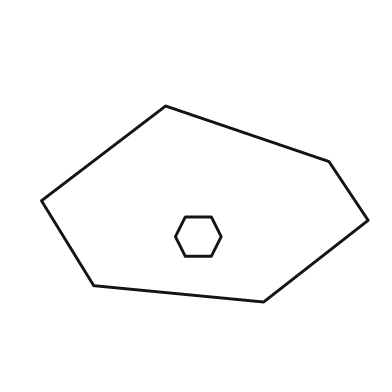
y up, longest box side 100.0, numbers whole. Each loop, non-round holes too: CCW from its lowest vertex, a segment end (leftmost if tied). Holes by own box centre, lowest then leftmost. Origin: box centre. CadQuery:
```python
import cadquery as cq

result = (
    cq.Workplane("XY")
    .moveTo(18.0, -30.0)
    .lineTo(50.0, -5.0)
    .lineTo(38.0, 13.0)
    .lineTo(-12.0, 30.0)
    .lineTo(-50.0, 1.0)
    .lineTo(-34.0, -25.0)
    .close()
    .moveTo(-6.0, -16.0)
    .lineTo(2.0, -16.0)
    .lineTo(5.0, -10.0)
    .lineTo(2.0, -4.0)
    .lineTo(-6.0, -4.0)
    .lineTo(-9.0, -10.0)
    .close()
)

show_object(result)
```